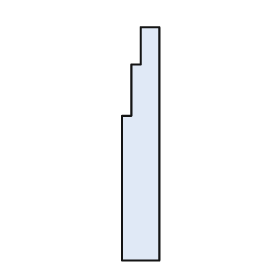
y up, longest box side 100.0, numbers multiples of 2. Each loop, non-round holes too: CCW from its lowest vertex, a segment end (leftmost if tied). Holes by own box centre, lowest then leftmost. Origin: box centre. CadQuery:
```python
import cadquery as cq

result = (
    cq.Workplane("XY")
    .moveTo(-8.0, -50.0)
    .lineTo(8.0, -50.0)
    .lineTo(8.0, 50.0)
    .lineTo(0.0, 50.0)
    .lineTo(0.0, 34.0)
    .lineTo(-4.0, 34.0)
    .lineTo(-4.0, 12.0)
    .lineTo(-8.0, 12.0)
    .close()
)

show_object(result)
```